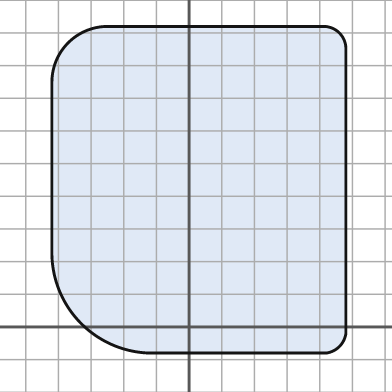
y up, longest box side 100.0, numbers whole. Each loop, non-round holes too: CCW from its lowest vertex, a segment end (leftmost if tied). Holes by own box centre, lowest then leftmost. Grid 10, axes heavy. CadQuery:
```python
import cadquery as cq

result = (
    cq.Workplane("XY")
    .moveTo(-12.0, -8.0)
    .lineTo(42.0, -8.0)
    .threePointArc((46.0, -6.0), (48.0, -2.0))
    .lineTo(48.0, 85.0)
    .threePointArc((46.0, 90.0), (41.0, 92.0))
    .lineTo(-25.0, 92.0)
    .threePointArc((-37.0, 87.0), (-42.0, 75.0))
    .lineTo(-42.0, 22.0)
    .threePointArc((-33.0, 1.0), (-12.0, -8.0))
    .close()
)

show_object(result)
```